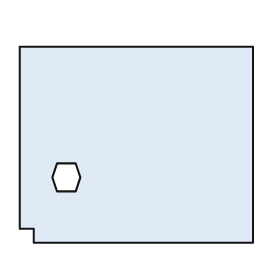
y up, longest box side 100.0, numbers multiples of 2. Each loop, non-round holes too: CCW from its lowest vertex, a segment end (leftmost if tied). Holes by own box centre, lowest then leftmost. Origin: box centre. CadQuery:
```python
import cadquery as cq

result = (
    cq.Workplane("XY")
    .moveTo(-44.0, -42.0)
    .lineTo(50.0, -42.0)
    .lineTo(50.0, 42.0)
    .lineTo(-50.0, 42.0)
    .lineTo(-50.0, -36.0)
    .lineTo(-44.0, -36.0)
    .close()
    .moveTo(-34.0, -20.0)
    .lineTo(-26.0, -20.0)
    .lineTo(-24.0, -14.0)
    .lineTo(-26.0, -8.0)
    .lineTo(-34.0, -8.0)
    .lineTo(-36.0, -14.0)
    .close()
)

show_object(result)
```